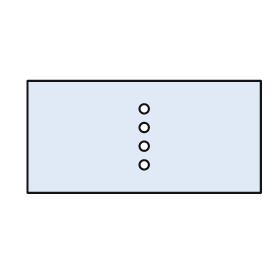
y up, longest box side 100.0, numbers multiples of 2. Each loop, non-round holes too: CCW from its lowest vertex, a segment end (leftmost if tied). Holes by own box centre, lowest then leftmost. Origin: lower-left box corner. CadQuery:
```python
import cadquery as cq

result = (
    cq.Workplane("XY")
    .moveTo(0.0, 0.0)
    .lineTo(100.0, 0.0)
    .lineTo(100.0, 48.0)
    .lineTo(0.0, 48.0)
    .close()
    .moveTo(50.0, 12.0)
    .circle(2.0)
    .moveTo(50.0, 20.0)
    .circle(2.0)
    .moveTo(50.0, 28.0)
    .circle(2.0)
    .moveTo(50.0, 36.0)
    .circle(2.0)
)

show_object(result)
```